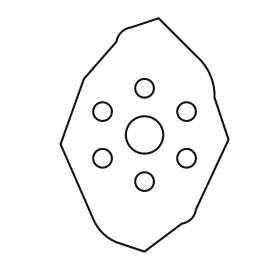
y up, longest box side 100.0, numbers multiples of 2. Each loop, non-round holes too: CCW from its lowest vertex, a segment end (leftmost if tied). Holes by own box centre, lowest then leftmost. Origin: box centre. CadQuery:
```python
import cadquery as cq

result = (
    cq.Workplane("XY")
    .moveTo(0.0, -50.0)
    .lineTo(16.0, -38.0)
    .threePointArc((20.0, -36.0), (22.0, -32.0))
    .lineTo(36.0, -2.0)
    .lineTo(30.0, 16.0)
    .threePointArc((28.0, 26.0), (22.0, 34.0))
    .lineTo(6.0, 50.0)
    .lineTo(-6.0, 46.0)
    .threePointArc((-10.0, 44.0), (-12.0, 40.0))
    .lineTo(-26.0, 24.0)
    .lineTo(-36.0, -4.0)
    .lineTo(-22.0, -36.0)
    .threePointArc((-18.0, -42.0), (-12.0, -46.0))
    .close()
    .moveTo(0.0, -20.0)
    .circle(4.0)
    .moveTo(-18.0, -10.0)
    .circle(4.0)
    .moveTo(18.0, -10.0)
    .circle(4.0)
    .moveTo(0.0, 0.0)
    .circle(8.0)
    .moveTo(-18.0, 10.0)
    .circle(4.0)
    .moveTo(18.0, 10.0)
    .circle(4.0)
    .moveTo(0.0, 20.0)
    .circle(4.0)
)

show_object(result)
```